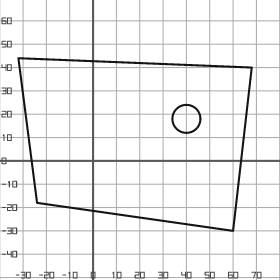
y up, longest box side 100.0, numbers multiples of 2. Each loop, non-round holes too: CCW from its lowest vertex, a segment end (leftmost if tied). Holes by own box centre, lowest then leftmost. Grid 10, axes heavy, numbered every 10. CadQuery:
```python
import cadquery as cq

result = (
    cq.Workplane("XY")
    .moveTo(60.0, -30.0)
    .lineTo(68.0, 40.0)
    .lineTo(-32.0, 44.0)
    .lineTo(-24.0, -18.0)
    .close()
    .moveTo(40.0, 18.0)
    .circle(6.0)
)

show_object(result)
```